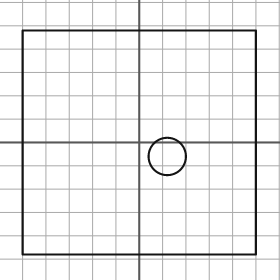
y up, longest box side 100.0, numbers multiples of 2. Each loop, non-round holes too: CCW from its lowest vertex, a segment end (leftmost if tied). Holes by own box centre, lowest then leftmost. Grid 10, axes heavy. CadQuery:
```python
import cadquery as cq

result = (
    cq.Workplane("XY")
    .moveTo(-50.0, -48.0)
    .lineTo(50.0, -48.0)
    .lineTo(50.0, 48.0)
    .lineTo(-50.0, 48.0)
    .close()
    .moveTo(12.0, -6.0)
    .circle(8.0)
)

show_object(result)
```